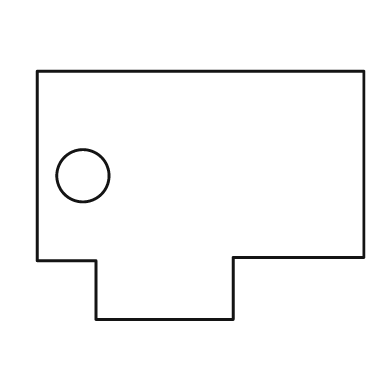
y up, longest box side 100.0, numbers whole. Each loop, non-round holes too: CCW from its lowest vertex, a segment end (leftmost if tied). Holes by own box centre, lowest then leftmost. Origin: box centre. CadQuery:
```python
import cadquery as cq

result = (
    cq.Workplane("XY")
    .moveTo(-32.0, -38.0)
    .lineTo(10.0, -38.0)
    .lineTo(10.0, -19.0)
    .lineTo(50.0, -19.0)
    .lineTo(50.0, 38.0)
    .lineTo(-50.0, 38.0)
    .lineTo(-50.0, -20.0)
    .lineTo(-32.0, -20.0)
    .close()
    .moveTo(-36.0, 6.0)
    .circle(8.0)
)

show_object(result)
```